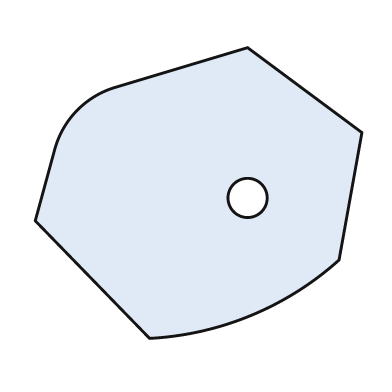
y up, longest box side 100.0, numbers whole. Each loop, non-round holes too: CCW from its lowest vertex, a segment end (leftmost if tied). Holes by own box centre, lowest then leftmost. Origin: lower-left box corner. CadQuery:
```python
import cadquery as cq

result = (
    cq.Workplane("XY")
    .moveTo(35.0, 0.0)
    .threePointArc((66.0, 7.0), (93.0, 24.0))
    .lineTo(100.0, 63.0)
    .lineTo(65.0, 89.0)
    .lineTo(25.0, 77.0)
    .threePointArc((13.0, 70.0), (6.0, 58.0))
    .lineTo(0.0, 36.0)
    .close()
    .moveTo(65.0, 43.0)
    .circle(6.0)
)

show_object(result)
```